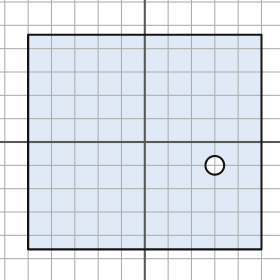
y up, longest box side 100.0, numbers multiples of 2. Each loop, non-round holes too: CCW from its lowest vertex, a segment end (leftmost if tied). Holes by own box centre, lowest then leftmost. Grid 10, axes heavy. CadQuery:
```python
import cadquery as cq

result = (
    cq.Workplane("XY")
    .moveTo(-50.0, -46.0)
    .lineTo(50.0, -46.0)
    .lineTo(50.0, 46.0)
    .lineTo(-50.0, 46.0)
    .close()
    .moveTo(30.0, -10.0)
    .circle(4.0)
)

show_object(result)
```